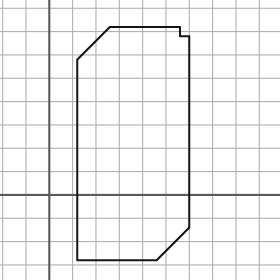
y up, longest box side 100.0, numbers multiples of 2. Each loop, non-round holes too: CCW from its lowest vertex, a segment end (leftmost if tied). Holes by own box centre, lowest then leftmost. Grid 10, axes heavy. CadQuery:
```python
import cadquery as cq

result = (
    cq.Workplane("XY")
    .moveTo(12.0, -28.0)
    .lineTo(46.0, -28.0)
    .lineTo(60.0, -14.0)
    .lineTo(60.0, 68.0)
    .lineTo(56.0, 68.0)
    .lineTo(56.0, 72.0)
    .lineTo(26.0, 72.0)
    .lineTo(12.0, 58.0)
    .close()
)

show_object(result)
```